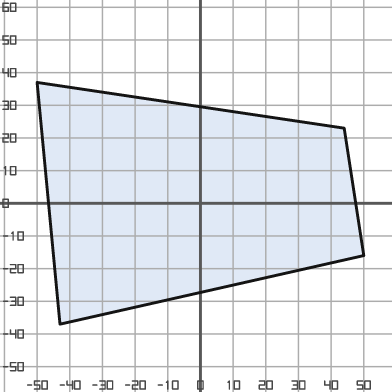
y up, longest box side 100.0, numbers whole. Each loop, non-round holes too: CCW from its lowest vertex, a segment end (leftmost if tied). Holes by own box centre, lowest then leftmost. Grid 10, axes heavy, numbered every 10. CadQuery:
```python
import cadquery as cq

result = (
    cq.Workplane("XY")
    .moveTo(-43.0, -37.0)
    .lineTo(50.0, -16.0)
    .lineTo(44.0, 23.0)
    .lineTo(-50.0, 37.0)
    .close()
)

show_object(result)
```